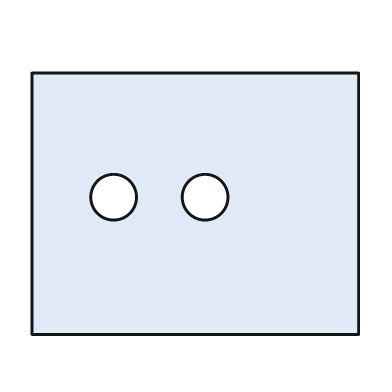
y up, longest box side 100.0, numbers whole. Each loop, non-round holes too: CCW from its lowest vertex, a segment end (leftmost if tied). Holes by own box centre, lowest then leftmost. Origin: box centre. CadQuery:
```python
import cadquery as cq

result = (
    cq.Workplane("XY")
    .moveTo(-50.0, -40.0)
    .lineTo(50.0, -40.0)
    .lineTo(50.0, 40.0)
    .lineTo(-50.0, 40.0)
    .close()
    .moveTo(-25.0, 2.0)
    .circle(7.0)
    .moveTo(3.0, 2.0)
    .circle(7.0)
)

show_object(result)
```